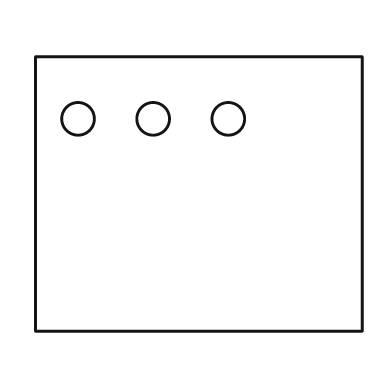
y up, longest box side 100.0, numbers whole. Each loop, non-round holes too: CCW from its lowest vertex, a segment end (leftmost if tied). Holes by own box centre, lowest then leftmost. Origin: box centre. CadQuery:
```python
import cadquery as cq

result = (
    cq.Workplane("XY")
    .moveTo(-50.0, -42.0)
    .lineTo(50.0, -42.0)
    .lineTo(50.0, 42.0)
    .lineTo(-50.0, 42.0)
    .close()
    .moveTo(-37.0, 23.0)
    .circle(5.0)
    .moveTo(-14.0, 23.0)
    .circle(5.0)
    .moveTo(9.0, 23.0)
    .circle(5.0)
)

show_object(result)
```